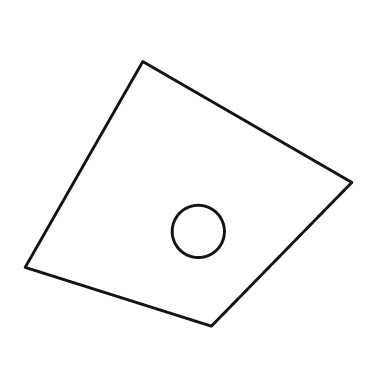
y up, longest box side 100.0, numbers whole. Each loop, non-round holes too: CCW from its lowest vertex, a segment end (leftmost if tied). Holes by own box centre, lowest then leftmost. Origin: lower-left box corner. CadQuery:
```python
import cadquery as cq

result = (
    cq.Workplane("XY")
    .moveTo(57.0, 0.0)
    .lineTo(100.0, 44.0)
    .lineTo(36.0, 81.0)
    .lineTo(0.0, 18.0)
    .close()
    .moveTo(53.0, 29.0)
    .circle(8.0)
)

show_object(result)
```